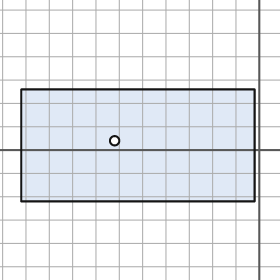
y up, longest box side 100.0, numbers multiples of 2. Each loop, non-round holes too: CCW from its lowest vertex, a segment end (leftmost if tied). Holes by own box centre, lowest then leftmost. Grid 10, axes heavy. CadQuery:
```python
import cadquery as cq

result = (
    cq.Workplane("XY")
    .moveTo(-102.0, -22.0)
    .lineTo(-2.0, -22.0)
    .lineTo(-2.0, 26.0)
    .lineTo(-102.0, 26.0)
    .close()
    .moveTo(-62.0, 4.0)
    .circle(2.0)
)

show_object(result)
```